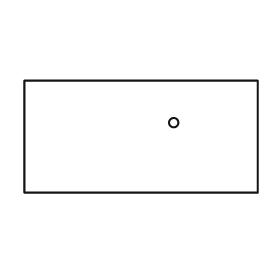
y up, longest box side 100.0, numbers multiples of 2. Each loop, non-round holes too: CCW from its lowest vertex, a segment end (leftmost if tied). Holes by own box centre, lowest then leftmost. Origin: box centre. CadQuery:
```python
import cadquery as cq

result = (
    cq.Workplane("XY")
    .moveTo(-50.0, -24.0)
    .lineTo(50.0, -24.0)
    .lineTo(50.0, 24.0)
    .lineTo(-50.0, 24.0)
    .close()
    .moveTo(14.0, 6.0)
    .circle(2.0)
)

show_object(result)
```